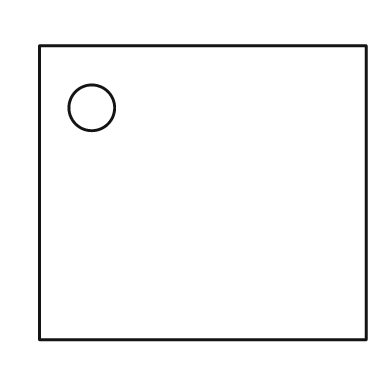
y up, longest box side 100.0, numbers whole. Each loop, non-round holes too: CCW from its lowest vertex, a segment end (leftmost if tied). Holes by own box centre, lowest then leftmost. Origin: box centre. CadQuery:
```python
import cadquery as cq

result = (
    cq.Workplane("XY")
    .moveTo(-50.0, -45.0)
    .lineTo(50.0, -45.0)
    .lineTo(50.0, 45.0)
    .lineTo(-50.0, 45.0)
    .close()
    .moveTo(-34.0, 26.0)
    .circle(7.0)
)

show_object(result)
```